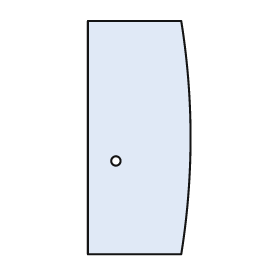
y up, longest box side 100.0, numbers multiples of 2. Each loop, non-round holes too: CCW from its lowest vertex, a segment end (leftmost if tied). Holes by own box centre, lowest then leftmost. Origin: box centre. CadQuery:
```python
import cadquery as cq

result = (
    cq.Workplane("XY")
    .moveTo(-22.0, -50.0)
    .lineTo(18.0, -50.0)
    .threePointArc((22.0, 0.0), (18.0, 50.0))
    .lineTo(-22.0, 50.0)
    .close()
    .moveTo(-10.0, -10.0)
    .circle(2.0)
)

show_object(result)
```